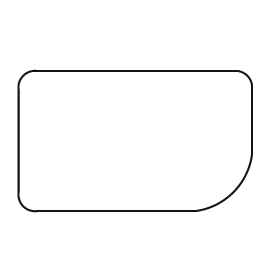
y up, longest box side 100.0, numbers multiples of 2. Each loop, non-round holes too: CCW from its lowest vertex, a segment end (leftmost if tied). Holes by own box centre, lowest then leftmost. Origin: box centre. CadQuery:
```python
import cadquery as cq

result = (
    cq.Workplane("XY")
    .moveTo(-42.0, -30.0)
    .lineTo(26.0, -30.0)
    .threePointArc((42.0, -22.0), (50.0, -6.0))
    .lineTo(50.0, 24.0)
    .threePointArc((48.0, 28.0), (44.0, 30.0))
    .lineTo(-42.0, 30.0)
    .threePointArc((-48.0, 28.0), (-50.0, 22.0))
    .lineTo(-50.0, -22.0)
    .threePointArc((-48.0, -28.0), (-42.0, -30.0))
    .close()
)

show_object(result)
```